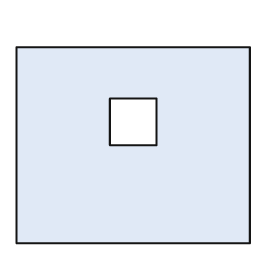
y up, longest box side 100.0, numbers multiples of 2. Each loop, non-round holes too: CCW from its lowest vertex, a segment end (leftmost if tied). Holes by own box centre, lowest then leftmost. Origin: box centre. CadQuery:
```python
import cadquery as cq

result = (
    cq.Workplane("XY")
    .moveTo(-50.0, -42.0)
    .lineTo(50.0, -42.0)
    .lineTo(50.0, 42.0)
    .lineTo(-50.0, 42.0)
    .close()
    .moveTo(-10.0, 0.0)
    .lineTo(10.0, 0.0)
    .lineTo(10.0, 20.0)
    .lineTo(-10.0, 20.0)
    .close()
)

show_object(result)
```